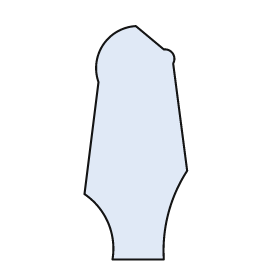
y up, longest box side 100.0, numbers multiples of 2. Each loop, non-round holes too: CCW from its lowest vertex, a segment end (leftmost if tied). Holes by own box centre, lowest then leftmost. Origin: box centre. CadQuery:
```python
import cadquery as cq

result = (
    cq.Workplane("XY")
    .moveTo(-10.0, -50.0)
    .lineTo(12.0, -50.0)
    .threePointArc((14.0, -30.0), (22.0, -12.0))
    .lineTo(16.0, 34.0)
    .threePointArc((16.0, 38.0), (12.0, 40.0))
    .lineTo(0.0, 50.0)
    .threePointArc((-14.0, 42.0), (-16.0, 26.0))
    .lineTo(-22.0, -22.0)
    .threePointArc((-12.0, -34.0), (-10.0, -50.0))
    .close()
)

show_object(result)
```